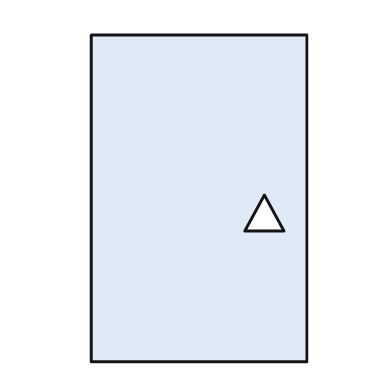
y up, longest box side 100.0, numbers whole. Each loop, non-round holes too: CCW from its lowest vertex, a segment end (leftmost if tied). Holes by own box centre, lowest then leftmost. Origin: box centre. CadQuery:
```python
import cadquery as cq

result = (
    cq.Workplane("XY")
    .moveTo(-33.0, -50.0)
    .lineTo(33.0, -50.0)
    .lineTo(33.0, 50.0)
    .lineTo(-33.0, 50.0)
    .close()
    .moveTo(14.0, -10.0)
    .lineTo(26.0, -10.0)
    .lineTo(20.0, 1.0)
    .close()
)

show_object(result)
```